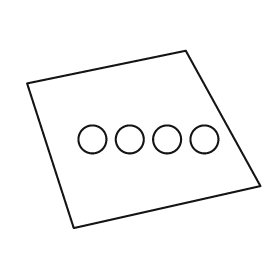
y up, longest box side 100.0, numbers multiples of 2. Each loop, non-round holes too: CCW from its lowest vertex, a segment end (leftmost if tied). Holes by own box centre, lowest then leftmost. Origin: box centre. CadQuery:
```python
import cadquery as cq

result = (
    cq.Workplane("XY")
    .moveTo(-30.0, -38.0)
    .lineTo(50.0, -20.0)
    .lineTo(18.0, 38.0)
    .lineTo(-50.0, 24.0)
    .close()
    .moveTo(-22.0, 0.0)
    .circle(6.0)
    .moveTo(-6.0, 0.0)
    .circle(6.0)
    .moveTo(10.0, 0.0)
    .circle(6.0)
    .moveTo(26.0, 0.0)
    .circle(6.0)
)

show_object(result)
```